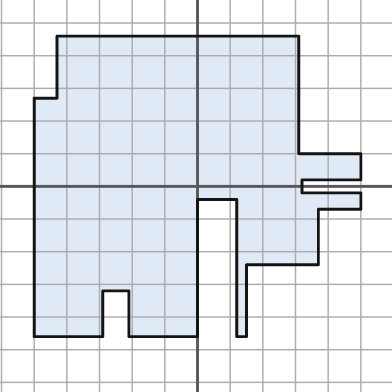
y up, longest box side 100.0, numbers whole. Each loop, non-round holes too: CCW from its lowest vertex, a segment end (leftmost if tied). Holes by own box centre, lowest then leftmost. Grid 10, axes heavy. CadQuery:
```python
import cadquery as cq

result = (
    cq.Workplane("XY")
    .moveTo(-50.0, -46.0)
    .lineTo(-29.0, -46.0)
    .lineTo(-29.0, -32.0)
    .lineTo(-21.0, -32.0)
    .lineTo(-21.0, -46.0)
    .lineTo(0.0, -46.0)
    .lineTo(0.0, -4.0)
    .lineTo(12.0, -4.0)
    .lineTo(12.0, -46.0)
    .lineTo(15.0, -46.0)
    .lineTo(15.0, -24.0)
    .lineTo(37.0, -24.0)
    .lineTo(37.0, -7.0)
    .lineTo(50.0, -7.0)
    .lineTo(50.0, -2.0)
    .lineTo(32.0, -2.0)
    .lineTo(32.0, 2.0)
    .lineTo(50.0, 2.0)
    .lineTo(50.0, 10.0)
    .lineTo(31.0, 10.0)
    .lineTo(31.0, 46.0)
    .lineTo(-43.0, 46.0)
    .lineTo(-43.0, 27.0)
    .lineTo(-50.0, 27.0)
    .close()
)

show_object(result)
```